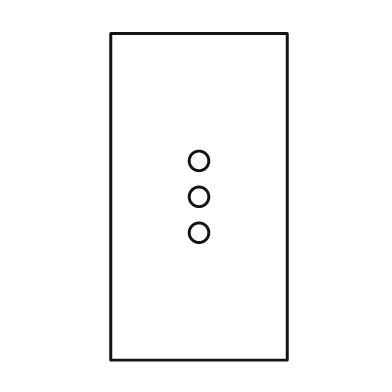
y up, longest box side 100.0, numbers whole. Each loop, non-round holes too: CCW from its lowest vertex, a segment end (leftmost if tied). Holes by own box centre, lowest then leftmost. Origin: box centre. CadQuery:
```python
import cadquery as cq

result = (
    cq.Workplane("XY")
    .moveTo(-27.0, -50.0)
    .lineTo(27.0, -50.0)
    .lineTo(27.0, 50.0)
    .lineTo(-27.0, 50.0)
    .close()
    .moveTo(0.0, -11.0)
    .circle(3.0)
    .moveTo(0.0, 0.0)
    .circle(3.0)
    .moveTo(0.0, 11.0)
    .circle(3.0)
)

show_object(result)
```